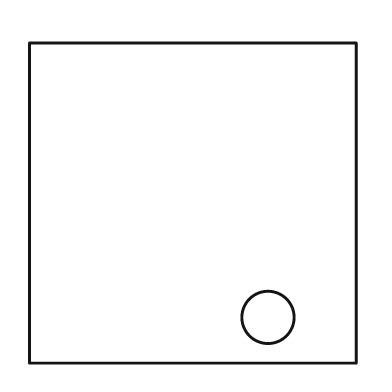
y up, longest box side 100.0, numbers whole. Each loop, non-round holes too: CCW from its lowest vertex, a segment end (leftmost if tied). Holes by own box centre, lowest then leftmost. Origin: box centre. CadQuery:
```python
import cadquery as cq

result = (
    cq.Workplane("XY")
    .moveTo(-50.0, -49.0)
    .lineTo(50.0, -49.0)
    .lineTo(50.0, 49.0)
    .lineTo(-50.0, 49.0)
    .close()
    .moveTo(23.0, -35.0)
    .circle(8.0)
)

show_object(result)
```